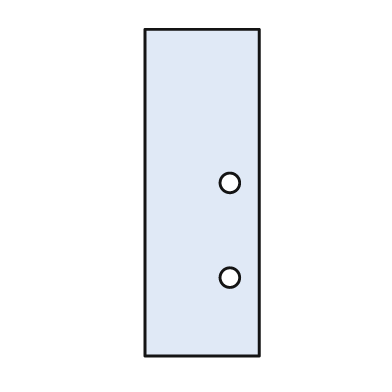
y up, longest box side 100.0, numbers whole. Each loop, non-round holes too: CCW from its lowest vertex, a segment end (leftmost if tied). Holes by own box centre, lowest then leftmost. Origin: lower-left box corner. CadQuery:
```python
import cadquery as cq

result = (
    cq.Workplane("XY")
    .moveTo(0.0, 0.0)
    .lineTo(35.0, 0.0)
    .lineTo(35.0, 100.0)
    .lineTo(0.0, 100.0)
    .close()
    .moveTo(26.0, 24.0)
    .circle(3.0)
    .moveTo(26.0, 53.0)
    .circle(3.0)
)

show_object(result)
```